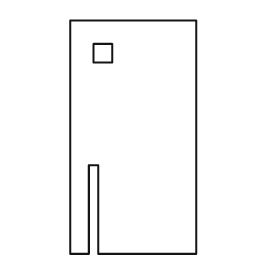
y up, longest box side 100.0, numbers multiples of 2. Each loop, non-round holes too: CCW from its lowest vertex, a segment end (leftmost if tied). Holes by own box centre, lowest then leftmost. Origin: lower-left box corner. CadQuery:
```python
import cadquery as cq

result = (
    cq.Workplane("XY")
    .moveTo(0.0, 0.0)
    .lineTo(8.0, 0.0)
    .lineTo(8.0, 38.0)
    .lineTo(12.0, 38.0)
    .lineTo(12.0, 0.0)
    .lineTo(54.0, 0.0)
    .lineTo(54.0, 100.0)
    .lineTo(0.0, 100.0)
    .close()
    .moveTo(10.0, 82.0)
    .lineTo(18.0, 82.0)
    .lineTo(18.0, 90.0)
    .lineTo(10.0, 90.0)
    .close()
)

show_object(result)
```